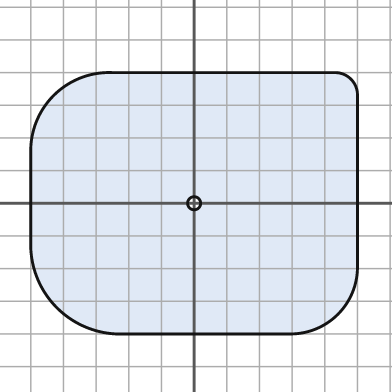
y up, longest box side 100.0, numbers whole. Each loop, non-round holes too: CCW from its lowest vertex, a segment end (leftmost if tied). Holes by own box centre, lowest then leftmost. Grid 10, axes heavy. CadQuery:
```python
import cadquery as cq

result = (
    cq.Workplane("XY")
    .moveTo(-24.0, -40.0)
    .lineTo(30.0, -40.0)
    .threePointArc((44.0, -34.0), (50.0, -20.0))
    .lineTo(50.0, 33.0)
    .threePointArc((48.0, 38.0), (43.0, 40.0))
    .lineTo(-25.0, 40.0)
    .threePointArc((-43.0, 33.0), (-50.0, 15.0))
    .lineTo(-50.0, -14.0)
    .threePointArc((-42.0, -32.0), (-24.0, -40.0))
    .close()
    .moveTo(0.0, 0.0)
    .circle(2.0)
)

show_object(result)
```